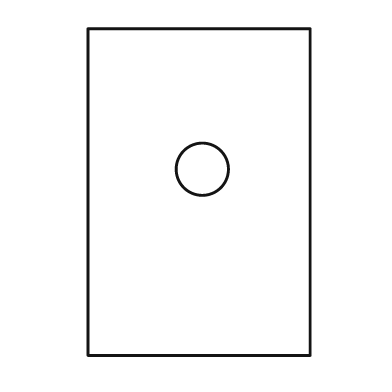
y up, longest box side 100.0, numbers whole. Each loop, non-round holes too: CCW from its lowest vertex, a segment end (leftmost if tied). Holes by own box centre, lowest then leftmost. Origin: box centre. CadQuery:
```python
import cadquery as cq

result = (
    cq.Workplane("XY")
    .moveTo(-34.0, -50.0)
    .lineTo(34.0, -50.0)
    .lineTo(34.0, 50.0)
    .lineTo(-34.0, 50.0)
    .close()
    .moveTo(1.0, 7.0)
    .circle(8.0)
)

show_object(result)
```